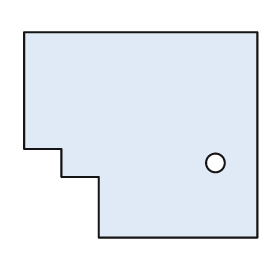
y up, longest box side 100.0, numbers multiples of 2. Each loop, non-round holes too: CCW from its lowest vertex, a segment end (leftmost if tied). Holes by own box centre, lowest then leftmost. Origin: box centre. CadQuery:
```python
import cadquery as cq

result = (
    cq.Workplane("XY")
    .moveTo(-18.0, -44.0)
    .lineTo(50.0, -44.0)
    .lineTo(50.0, 44.0)
    .lineTo(-50.0, 44.0)
    .lineTo(-50.0, -6.0)
    .lineTo(-34.0, -6.0)
    .lineTo(-34.0, -18.0)
    .lineTo(-18.0, -18.0)
    .close()
    .moveTo(32.0, -12.0)
    .circle(4.0)
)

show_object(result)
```